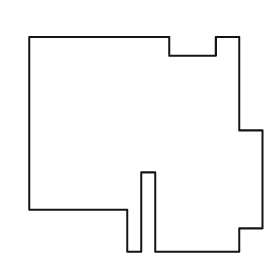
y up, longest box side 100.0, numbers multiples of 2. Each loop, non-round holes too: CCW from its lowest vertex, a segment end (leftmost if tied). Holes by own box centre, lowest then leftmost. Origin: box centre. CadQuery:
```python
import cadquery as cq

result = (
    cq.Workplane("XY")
    .moveTo(-8.0, -46.0)
    .lineTo(-2.0, -46.0)
    .lineTo(-2.0, -12.0)
    .lineTo(4.0, -12.0)
    .lineTo(4.0, -46.0)
    .lineTo(40.0, -46.0)
    .lineTo(40.0, -36.0)
    .lineTo(50.0, -36.0)
    .lineTo(50.0, 6.0)
    .lineTo(40.0, 6.0)
    .lineTo(40.0, 46.0)
    .lineTo(30.0, 46.0)
    .lineTo(30.0, 38.0)
    .lineTo(10.0, 38.0)
    .lineTo(10.0, 46.0)
    .lineTo(-50.0, 46.0)
    .lineTo(-50.0, -28.0)
    .lineTo(-8.0, -28.0)
    .close()
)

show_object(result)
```